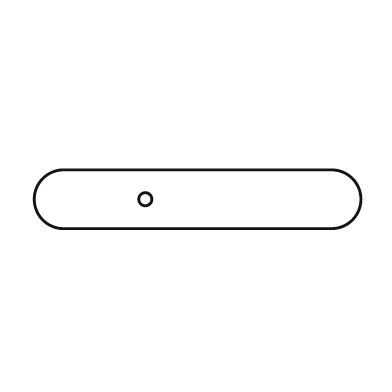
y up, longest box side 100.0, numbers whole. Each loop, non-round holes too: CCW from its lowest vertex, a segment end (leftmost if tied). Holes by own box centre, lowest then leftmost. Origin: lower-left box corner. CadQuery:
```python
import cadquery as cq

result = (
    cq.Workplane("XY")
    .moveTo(9.0, 0.0)
    .lineTo(91.0, 0.0)
    .threePointArc((100.0, 9.0), (91.0, 18.0))
    .lineTo(9.0, 18.0)
    .threePointArc((0.0, 9.0), (9.0, 0.0))
    .close()
    .moveTo(34.0, 9.0)
    .circle(2.0)
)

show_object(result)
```